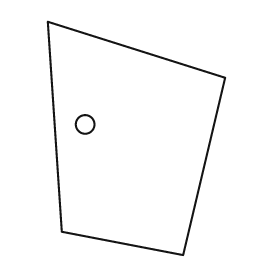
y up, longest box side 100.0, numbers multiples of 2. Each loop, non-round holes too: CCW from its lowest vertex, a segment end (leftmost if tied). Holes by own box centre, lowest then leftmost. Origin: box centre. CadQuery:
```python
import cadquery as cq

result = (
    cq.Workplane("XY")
    .moveTo(20.0, -50.0)
    .lineTo(38.0, 26.0)
    .lineTo(-38.0, 50.0)
    .lineTo(-32.0, -40.0)
    .close()
    .moveTo(-22.0, 6.0)
    .circle(4.0)
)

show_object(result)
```